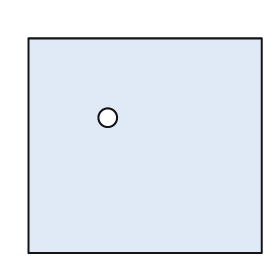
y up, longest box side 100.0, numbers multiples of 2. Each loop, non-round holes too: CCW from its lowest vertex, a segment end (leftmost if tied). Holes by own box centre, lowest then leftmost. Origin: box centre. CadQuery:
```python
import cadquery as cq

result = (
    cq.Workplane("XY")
    .moveTo(-50.0, -46.0)
    .lineTo(50.0, -46.0)
    .lineTo(50.0, 46.0)
    .lineTo(-50.0, 46.0)
    .close()
    .moveTo(-16.0, 12.0)
    .circle(4.0)
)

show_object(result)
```